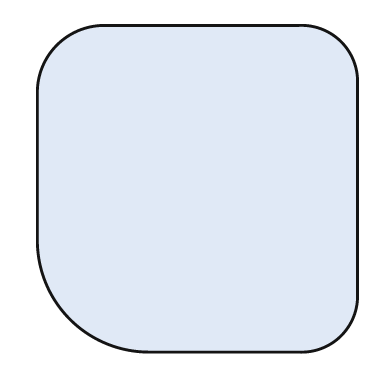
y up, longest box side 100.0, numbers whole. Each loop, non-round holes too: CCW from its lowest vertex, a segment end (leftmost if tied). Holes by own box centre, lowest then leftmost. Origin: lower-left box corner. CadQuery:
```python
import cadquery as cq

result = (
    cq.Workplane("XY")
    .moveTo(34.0, 0.0)
    .lineTo(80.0, 0.0)
    .threePointArc((93.0, 5.0), (98.0, 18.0))
    .lineTo(98.0, 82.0)
    .threePointArc((93.0, 95.0), (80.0, 100.0))
    .lineTo(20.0, 100.0)
    .threePointArc((6.0, 94.0), (0.0, 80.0))
    .lineTo(0.0, 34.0)
    .threePointArc((10.0, 10.0), (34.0, 0.0))
    .close()
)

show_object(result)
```